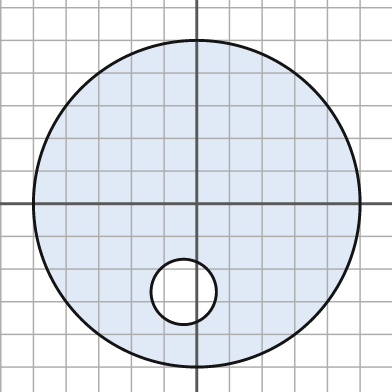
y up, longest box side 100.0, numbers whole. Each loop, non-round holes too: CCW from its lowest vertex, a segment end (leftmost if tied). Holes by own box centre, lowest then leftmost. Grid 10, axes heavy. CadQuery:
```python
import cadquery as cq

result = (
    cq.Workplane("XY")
    .moveTo(0.0, 0.0)
    .circle(50.0)
    .moveTo(-4.0, -27.0)
    .circle(10.0)
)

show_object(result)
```